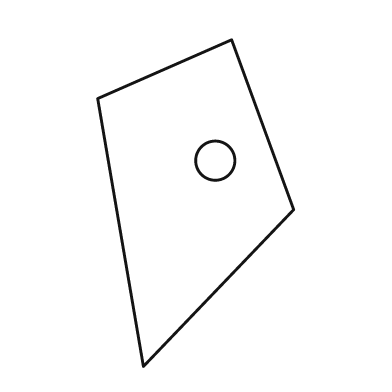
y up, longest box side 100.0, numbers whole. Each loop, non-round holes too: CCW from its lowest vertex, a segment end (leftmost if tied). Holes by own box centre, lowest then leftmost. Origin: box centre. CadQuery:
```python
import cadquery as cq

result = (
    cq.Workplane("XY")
    .moveTo(-16.0, -50.0)
    .lineTo(30.0, -2.0)
    .lineTo(11.0, 50.0)
    .lineTo(-30.0, 32.0)
    .close()
    .moveTo(6.0, 13.0)
    .circle(6.0)
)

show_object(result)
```